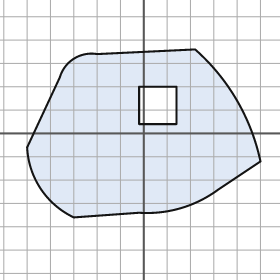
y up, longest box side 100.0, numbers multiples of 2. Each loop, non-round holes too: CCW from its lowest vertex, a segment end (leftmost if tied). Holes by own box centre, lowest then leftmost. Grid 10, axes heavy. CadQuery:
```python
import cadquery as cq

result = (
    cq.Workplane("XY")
    .moveTo(-30.0, -36.0)
    .lineTo(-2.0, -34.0)
    .threePointArc((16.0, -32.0), (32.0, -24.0))
    .lineTo(50.0, -12.0)
    .threePointArc((40.0, 14.0), (22.0, 36.0))
    .lineTo(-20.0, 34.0)
    .threePointArc((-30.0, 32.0), (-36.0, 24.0))
    .lineTo(-50.0, -6.0)
    .threePointArc((-44.0, -24.0), (-30.0, -36.0))
    .close()
    .moveTo(-2.0, 4.0)
    .lineTo(14.0, 4.0)
    .lineTo(14.0, 20.0)
    .lineTo(-2.0, 20.0)
    .close()
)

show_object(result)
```